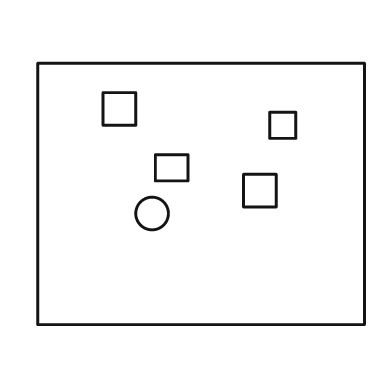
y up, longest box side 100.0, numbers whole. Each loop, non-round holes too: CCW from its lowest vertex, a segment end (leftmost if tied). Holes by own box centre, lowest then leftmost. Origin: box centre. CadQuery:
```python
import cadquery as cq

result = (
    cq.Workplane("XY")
    .moveTo(-50.0, -40.0)
    .lineTo(50.0, -40.0)
    .lineTo(50.0, 40.0)
    .lineTo(-50.0, 40.0)
    .close()
    .moveTo(-15.0, -6.0)
    .circle(5.0)
    .moveTo(13.0, -4.0)
    .lineTo(23.0, -4.0)
    .lineTo(23.0, 6.0)
    .lineTo(13.0, 6.0)
    .close()
    .moveTo(-14.0, 4.0)
    .lineTo(-4.0, 4.0)
    .lineTo(-4.0, 12.0)
    .lineTo(-14.0, 12.0)
    .close()
    .moveTo(21.0, 17.0)
    .lineTo(29.0, 17.0)
    .lineTo(29.0, 25.0)
    .lineTo(21.0, 25.0)
    .close()
    .moveTo(-30.0, 21.0)
    .lineTo(-20.0, 21.0)
    .lineTo(-20.0, 31.0)
    .lineTo(-30.0, 31.0)
    .close()
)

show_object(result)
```